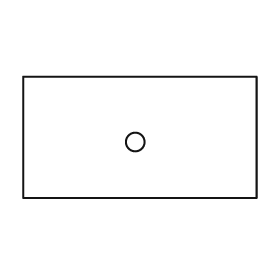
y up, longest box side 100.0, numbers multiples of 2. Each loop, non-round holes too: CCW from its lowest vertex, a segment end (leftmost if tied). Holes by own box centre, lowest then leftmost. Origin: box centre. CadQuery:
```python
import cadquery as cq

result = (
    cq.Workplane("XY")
    .moveTo(-50.0, -26.0)
    .lineTo(50.0, -26.0)
    .lineTo(50.0, 26.0)
    .lineTo(-50.0, 26.0)
    .close()
    .moveTo(-2.0, -2.0)
    .circle(4.0)
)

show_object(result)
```